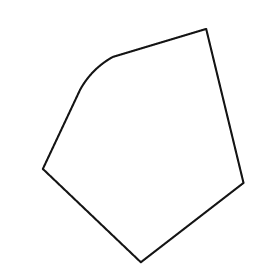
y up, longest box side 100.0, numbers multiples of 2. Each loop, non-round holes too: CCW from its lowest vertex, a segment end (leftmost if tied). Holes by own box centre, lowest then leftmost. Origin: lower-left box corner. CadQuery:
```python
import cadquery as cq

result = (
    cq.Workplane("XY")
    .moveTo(42.0, 0.0)
    .lineTo(86.0, 34.0)
    .lineTo(70.0, 100.0)
    .lineTo(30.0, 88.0)
    .threePointArc((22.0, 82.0), (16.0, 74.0))
    .lineTo(0.0, 40.0)
    .close()
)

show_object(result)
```